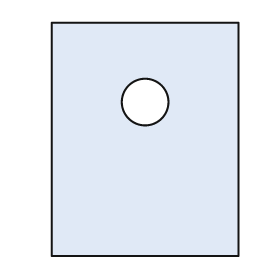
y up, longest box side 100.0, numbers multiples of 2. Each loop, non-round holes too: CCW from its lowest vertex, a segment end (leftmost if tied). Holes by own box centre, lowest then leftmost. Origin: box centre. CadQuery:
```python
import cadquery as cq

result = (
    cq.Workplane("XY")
    .moveTo(-40.0, -50.0)
    .lineTo(40.0, -50.0)
    .lineTo(40.0, 50.0)
    .lineTo(-40.0, 50.0)
    .close()
    .moveTo(0.0, 16.0)
    .circle(10.0)
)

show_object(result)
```